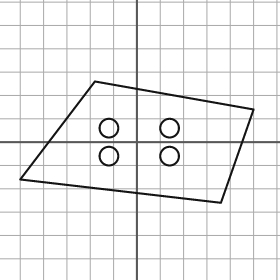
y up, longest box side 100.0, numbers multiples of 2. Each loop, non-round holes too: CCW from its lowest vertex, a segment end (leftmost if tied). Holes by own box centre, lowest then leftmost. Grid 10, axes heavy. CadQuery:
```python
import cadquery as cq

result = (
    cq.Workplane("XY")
    .moveTo(36.0, -26.0)
    .lineTo(50.0, 14.0)
    .lineTo(-18.0, 26.0)
    .lineTo(-50.0, -16.0)
    .close()
    .moveTo(-12.0, -6.0)
    .circle(4.0)
    .moveTo(14.0, -6.0)
    .circle(4.0)
    .moveTo(-12.0, 6.0)
    .circle(4.0)
    .moveTo(14.0, 6.0)
    .circle(4.0)
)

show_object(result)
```